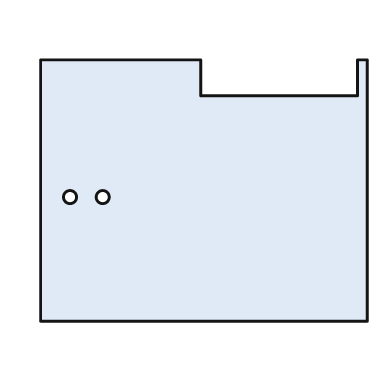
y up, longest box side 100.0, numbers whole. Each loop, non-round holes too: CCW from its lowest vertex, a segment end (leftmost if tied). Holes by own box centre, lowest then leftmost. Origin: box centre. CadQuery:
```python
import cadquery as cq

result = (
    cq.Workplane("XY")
    .moveTo(-50.0, -40.0)
    .lineTo(50.0, -40.0)
    .lineTo(50.0, 40.0)
    .lineTo(47.0, 40.0)
    .lineTo(47.0, 29.0)
    .lineTo(-1.0, 29.0)
    .lineTo(-1.0, 40.0)
    .lineTo(-50.0, 40.0)
    .close()
    .moveTo(-41.0, -2.0)
    .circle(2.0)
    .moveTo(-31.0, -2.0)
    .circle(2.0)
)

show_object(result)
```